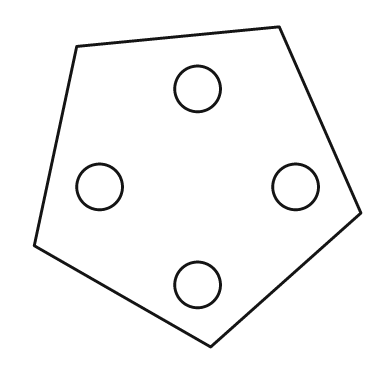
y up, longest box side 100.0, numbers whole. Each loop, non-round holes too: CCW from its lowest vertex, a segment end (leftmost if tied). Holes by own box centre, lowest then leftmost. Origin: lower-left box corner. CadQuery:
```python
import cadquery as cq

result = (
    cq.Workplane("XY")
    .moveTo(54.0, 0.0)
    .lineTo(100.0, 41.0)
    .lineTo(75.0, 98.0)
    .lineTo(13.0, 92.0)
    .lineTo(0.0, 31.0)
    .close()
    .moveTo(50.0, 19.0)
    .circle(7.0)
    .moveTo(20.0, 49.0)
    .circle(7.0)
    .moveTo(80.0, 49.0)
    .circle(7.0)
    .moveTo(50.0, 79.0)
    .circle(7.0)
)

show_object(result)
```